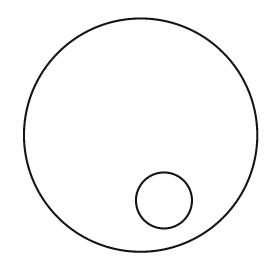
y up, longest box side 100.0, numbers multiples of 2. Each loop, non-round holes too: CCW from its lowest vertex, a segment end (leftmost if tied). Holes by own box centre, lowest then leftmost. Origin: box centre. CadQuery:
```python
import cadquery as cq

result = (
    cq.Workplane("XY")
    .moveTo(0.0, 0.0)
    .circle(50.0)
    .moveTo(10.0, -28.0)
    .circle(12.0)
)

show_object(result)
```